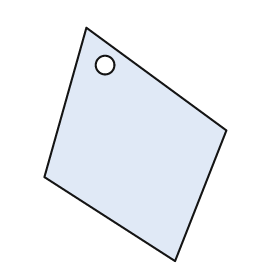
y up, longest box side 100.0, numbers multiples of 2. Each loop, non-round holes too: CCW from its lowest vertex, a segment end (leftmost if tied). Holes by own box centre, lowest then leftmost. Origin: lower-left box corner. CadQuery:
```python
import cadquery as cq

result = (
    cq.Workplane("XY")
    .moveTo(56.0, 0.0)
    .lineTo(78.0, 56.0)
    .lineTo(18.0, 100.0)
    .lineTo(0.0, 36.0)
    .close()
    .moveTo(26.0, 84.0)
    .circle(4.0)
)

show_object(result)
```